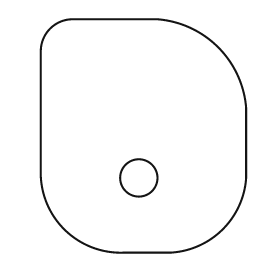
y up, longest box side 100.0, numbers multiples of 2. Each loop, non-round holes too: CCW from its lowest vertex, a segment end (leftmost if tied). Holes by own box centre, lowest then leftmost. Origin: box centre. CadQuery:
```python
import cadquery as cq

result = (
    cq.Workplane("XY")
    .moveTo(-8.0, -50.0)
    .lineTo(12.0, -50.0)
    .threePointArc((34.0, -40.0), (44.0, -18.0))
    .lineTo(44.0, 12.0)
    .threePointArc((32.0, 38.0), (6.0, 50.0))
    .lineTo(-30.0, 50.0)
    .threePointArc((-40.0, 46.0), (-44.0, 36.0))
    .lineTo(-44.0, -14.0)
    .threePointArc((-34.0, -40.0), (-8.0, -50.0))
    .close()
    .moveTo(-2.0, -18.0)
    .circle(8.0)
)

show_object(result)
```